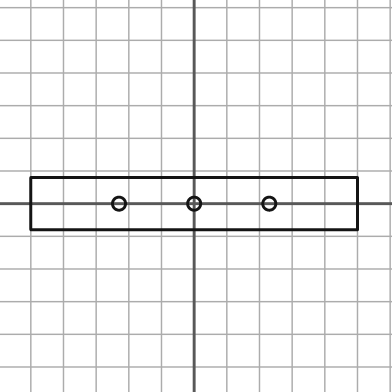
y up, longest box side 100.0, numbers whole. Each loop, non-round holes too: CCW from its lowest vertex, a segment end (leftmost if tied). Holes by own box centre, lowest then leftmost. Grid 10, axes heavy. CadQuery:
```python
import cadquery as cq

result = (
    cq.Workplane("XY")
    .moveTo(-50.0, -8.0)
    .lineTo(50.0, -8.0)
    .lineTo(50.0, 8.0)
    .lineTo(-50.0, 8.0)
    .close()
    .moveTo(-23.0, 0.0)
    .circle(2.0)
    .moveTo(0.0, 0.0)
    .circle(2.0)
    .moveTo(23.0, 0.0)
    .circle(2.0)
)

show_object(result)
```